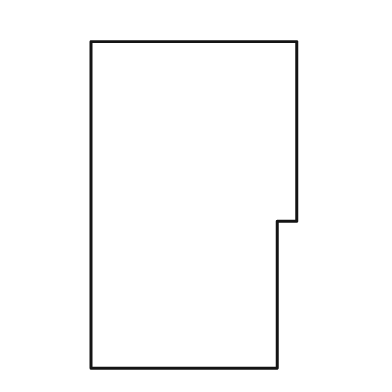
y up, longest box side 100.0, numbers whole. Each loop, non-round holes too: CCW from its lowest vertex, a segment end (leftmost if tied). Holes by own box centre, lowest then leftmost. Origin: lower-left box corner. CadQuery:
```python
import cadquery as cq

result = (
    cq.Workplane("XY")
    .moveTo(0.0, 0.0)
    .lineTo(57.0, 0.0)
    .lineTo(57.0, 45.0)
    .lineTo(63.0, 45.0)
    .lineTo(63.0, 100.0)
    .lineTo(0.0, 100.0)
    .close()
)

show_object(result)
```